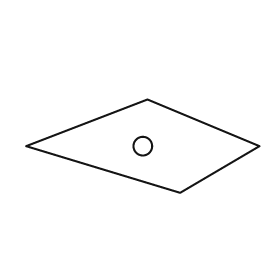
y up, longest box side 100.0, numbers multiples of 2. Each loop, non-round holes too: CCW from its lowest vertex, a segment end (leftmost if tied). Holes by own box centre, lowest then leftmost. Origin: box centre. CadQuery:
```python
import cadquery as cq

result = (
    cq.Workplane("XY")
    .moveTo(16.0, -20.0)
    .lineTo(50.0, 0.0)
    .lineTo(2.0, 20.0)
    .lineTo(-50.0, 0.0)
    .close()
    .moveTo(0.0, 0.0)
    .circle(4.0)
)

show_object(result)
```